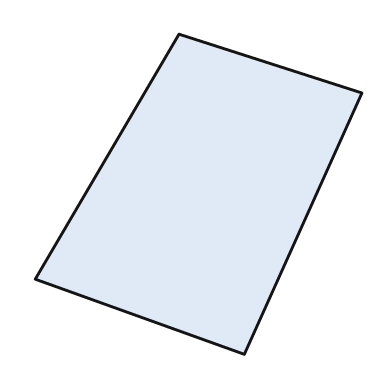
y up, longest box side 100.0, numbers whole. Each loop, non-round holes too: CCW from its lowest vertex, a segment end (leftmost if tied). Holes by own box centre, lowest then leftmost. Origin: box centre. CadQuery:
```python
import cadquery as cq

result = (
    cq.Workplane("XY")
    .moveTo(14.0, -49.0)
    .lineTo(50.0, 31.0)
    .lineTo(-6.0, 49.0)
    .lineTo(-50.0, -26.0)
    .close()
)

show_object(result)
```